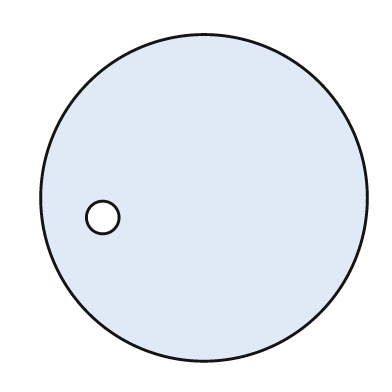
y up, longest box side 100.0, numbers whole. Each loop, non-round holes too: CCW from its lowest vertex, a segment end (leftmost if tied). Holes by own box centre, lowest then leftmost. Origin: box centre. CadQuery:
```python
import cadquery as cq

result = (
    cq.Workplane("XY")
    .moveTo(0.0, 0.0)
    .circle(50.0)
    .moveTo(-31.0, -6.0)
    .circle(5.0)
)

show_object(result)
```